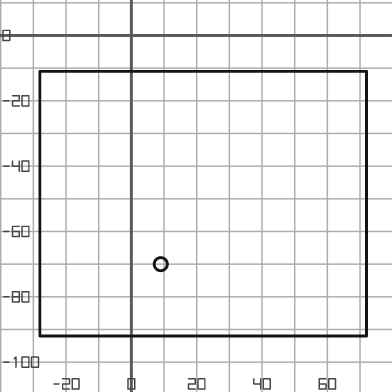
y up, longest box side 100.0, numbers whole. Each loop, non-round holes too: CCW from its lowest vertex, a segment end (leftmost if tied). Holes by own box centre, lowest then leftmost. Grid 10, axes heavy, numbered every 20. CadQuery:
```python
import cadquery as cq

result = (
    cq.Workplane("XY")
    .moveTo(-28.0, -92.0)
    .lineTo(72.0, -92.0)
    .lineTo(72.0, -11.0)
    .lineTo(-28.0, -11.0)
    .close()
    .moveTo(9.0, -70.0)
    .circle(2.0)
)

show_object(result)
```